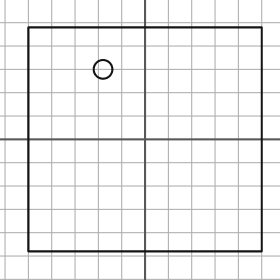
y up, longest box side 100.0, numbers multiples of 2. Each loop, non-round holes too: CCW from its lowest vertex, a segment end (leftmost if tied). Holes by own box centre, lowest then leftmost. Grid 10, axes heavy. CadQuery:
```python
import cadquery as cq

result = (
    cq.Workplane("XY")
    .moveTo(-50.0, -48.0)
    .lineTo(50.0, -48.0)
    .lineTo(50.0, 48.0)
    .lineTo(-50.0, 48.0)
    .close()
    .moveTo(-18.0, 30.0)
    .circle(4.0)
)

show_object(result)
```